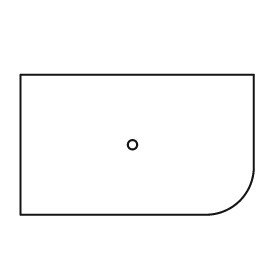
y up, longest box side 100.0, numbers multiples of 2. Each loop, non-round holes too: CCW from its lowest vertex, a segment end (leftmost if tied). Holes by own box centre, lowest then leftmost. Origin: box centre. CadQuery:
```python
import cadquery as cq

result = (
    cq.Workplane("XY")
    .moveTo(-50.0, -30.0)
    .lineTo(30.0, -30.0)
    .threePointArc((44.0, -24.0), (50.0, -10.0))
    .lineTo(50.0, 30.0)
    .lineTo(-50.0, 30.0)
    .close()
    .moveTo(-2.0, 0.0)
    .circle(2.0)
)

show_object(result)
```